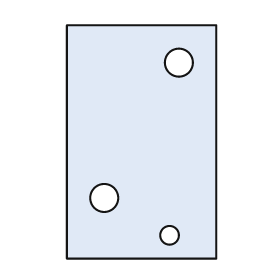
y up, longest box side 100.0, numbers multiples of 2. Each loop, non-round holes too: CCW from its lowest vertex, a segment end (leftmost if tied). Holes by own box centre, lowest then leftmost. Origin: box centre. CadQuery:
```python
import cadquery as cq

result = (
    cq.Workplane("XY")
    .moveTo(-32.0, -50.0)
    .lineTo(32.0, -50.0)
    .lineTo(32.0, 50.0)
    .lineTo(-32.0, 50.0)
    .close()
    .moveTo(12.0, -40.0)
    .circle(4.0)
    .moveTo(-16.0, -24.0)
    .circle(6.0)
    .moveTo(16.0, 34.0)
    .circle(6.0)
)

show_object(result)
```